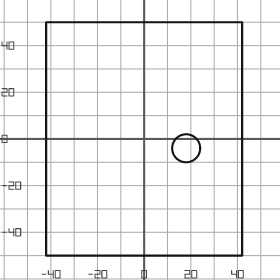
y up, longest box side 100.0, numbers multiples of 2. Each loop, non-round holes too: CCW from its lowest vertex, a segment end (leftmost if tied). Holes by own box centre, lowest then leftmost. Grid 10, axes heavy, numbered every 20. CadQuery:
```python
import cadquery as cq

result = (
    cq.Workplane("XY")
    .moveTo(-42.0, -50.0)
    .lineTo(42.0, -50.0)
    .lineTo(42.0, 50.0)
    .lineTo(-42.0, 50.0)
    .close()
    .moveTo(18.0, -4.0)
    .circle(6.0)
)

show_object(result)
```